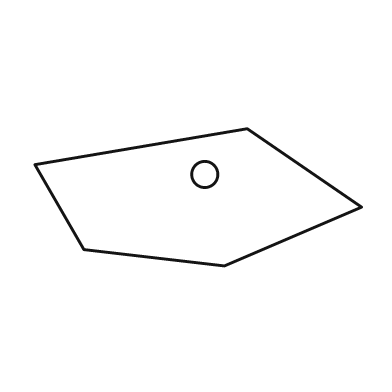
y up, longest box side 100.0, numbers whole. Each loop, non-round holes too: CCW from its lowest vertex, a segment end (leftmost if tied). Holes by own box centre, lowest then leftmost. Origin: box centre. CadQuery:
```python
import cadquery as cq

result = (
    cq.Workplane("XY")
    .moveTo(8.0, -21.0)
    .lineTo(50.0, -3.0)
    .lineTo(15.0, 21.0)
    .lineTo(-50.0, 10.0)
    .lineTo(-35.0, -16.0)
    .close()
    .moveTo(2.0, 7.0)
    .circle(4.0)
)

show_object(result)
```